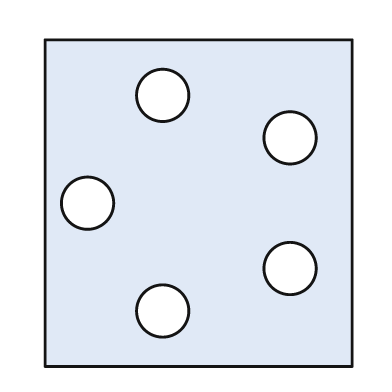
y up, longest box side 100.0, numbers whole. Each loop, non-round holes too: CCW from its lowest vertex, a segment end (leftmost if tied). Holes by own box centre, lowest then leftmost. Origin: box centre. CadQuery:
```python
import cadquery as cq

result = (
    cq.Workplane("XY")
    .moveTo(-47.0, -50.0)
    .lineTo(47.0, -50.0)
    .lineTo(47.0, 50.0)
    .lineTo(-47.0, 50.0)
    .close()
    .moveTo(-11.0, -33.0)
    .circle(8.0)
    .moveTo(28.0, -20.0)
    .circle(8.0)
    .moveTo(-34.0, 0.0)
    .circle(8.0)
    .moveTo(28.0, 20.0)
    .circle(8.0)
    .moveTo(-11.0, 33.0)
    .circle(8.0)
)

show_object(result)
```